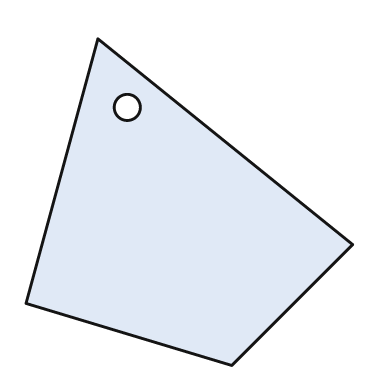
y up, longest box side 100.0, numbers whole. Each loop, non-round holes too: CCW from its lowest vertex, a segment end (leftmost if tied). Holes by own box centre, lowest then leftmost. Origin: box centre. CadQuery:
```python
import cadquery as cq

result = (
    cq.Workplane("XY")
    .moveTo(13.0, -50.0)
    .lineTo(50.0, -13.0)
    .lineTo(-28.0, 50.0)
    .lineTo(-50.0, -31.0)
    .close()
    .moveTo(-19.0, 29.0)
    .circle(4.0)
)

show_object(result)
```